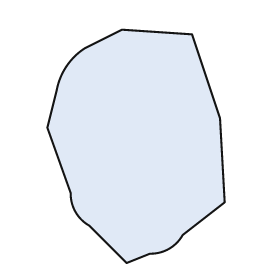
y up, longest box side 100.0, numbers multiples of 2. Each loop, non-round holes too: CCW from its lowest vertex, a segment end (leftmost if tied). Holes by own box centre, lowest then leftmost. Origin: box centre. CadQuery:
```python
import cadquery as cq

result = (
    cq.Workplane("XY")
    .moveTo(-4.0, -50.0)
    .lineTo(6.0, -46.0)
    .threePointArc((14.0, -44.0), (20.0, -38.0))
    .lineTo(38.0, -24.0)
    .lineTo(36.0, 12.0)
    .lineTo(24.0, 48.0)
    .lineTo(-6.0, 50.0)
    .lineTo(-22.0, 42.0)
    .threePointArc((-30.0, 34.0), (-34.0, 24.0))
    .lineTo(-38.0, 8.0)
    .lineTo(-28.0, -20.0)
    .threePointArc((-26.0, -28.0), (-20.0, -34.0))
    .close()
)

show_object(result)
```